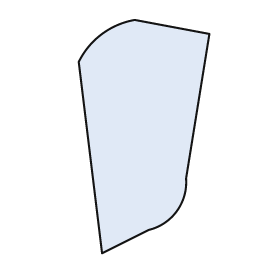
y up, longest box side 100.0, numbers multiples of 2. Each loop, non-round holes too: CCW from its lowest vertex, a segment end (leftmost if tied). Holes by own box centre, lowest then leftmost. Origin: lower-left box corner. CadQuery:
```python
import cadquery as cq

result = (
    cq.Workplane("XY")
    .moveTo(10.0, 0.0)
    .lineTo(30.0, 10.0)
    .threePointArc((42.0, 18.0), (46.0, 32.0))
    .lineTo(56.0, 94.0)
    .lineTo(24.0, 100.0)
    .threePointArc((10.0, 94.0), (0.0, 82.0))
    .close()
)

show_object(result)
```